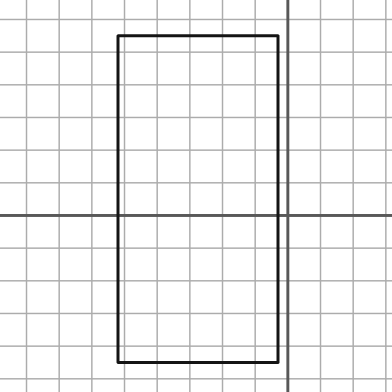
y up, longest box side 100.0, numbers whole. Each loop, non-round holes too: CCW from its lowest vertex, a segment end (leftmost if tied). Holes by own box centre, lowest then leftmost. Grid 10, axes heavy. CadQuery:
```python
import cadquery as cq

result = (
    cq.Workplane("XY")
    .moveTo(-52.0, -45.0)
    .lineTo(-3.0, -45.0)
    .lineTo(-3.0, 55.0)
    .lineTo(-52.0, 55.0)
    .close()
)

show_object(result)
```